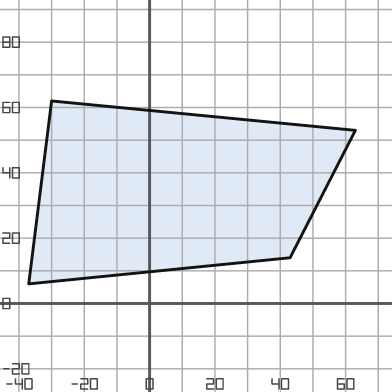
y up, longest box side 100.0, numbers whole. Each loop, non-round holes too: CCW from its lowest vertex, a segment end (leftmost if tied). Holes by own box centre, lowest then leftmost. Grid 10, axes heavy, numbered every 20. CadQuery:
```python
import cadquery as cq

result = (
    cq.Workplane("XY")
    .moveTo(-37.0, 6.0)
    .lineTo(43.0, 14.0)
    .lineTo(63.0, 53.0)
    .lineTo(-30.0, 62.0)
    .close()
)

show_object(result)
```